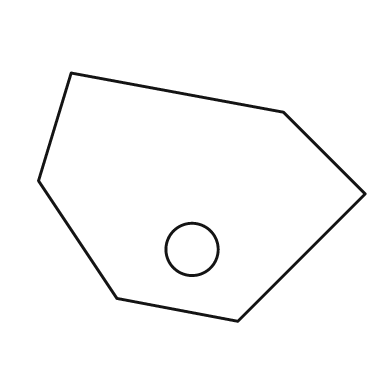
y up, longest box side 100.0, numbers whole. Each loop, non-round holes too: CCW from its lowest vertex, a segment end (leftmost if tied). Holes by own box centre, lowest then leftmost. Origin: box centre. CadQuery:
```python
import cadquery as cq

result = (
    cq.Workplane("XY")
    .moveTo(11.0, -38.0)
    .lineTo(50.0, 1.0)
    .lineTo(25.0, 26.0)
    .lineTo(-40.0, 38.0)
    .lineTo(-50.0, 5.0)
    .lineTo(-26.0, -31.0)
    .close()
    .moveTo(-3.0, -16.0)
    .circle(8.0)
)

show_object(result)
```